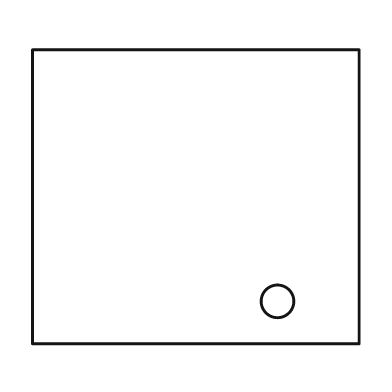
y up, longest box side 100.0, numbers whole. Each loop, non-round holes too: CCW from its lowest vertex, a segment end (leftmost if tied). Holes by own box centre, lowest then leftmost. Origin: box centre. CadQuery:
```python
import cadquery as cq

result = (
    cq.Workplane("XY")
    .moveTo(-50.0, -45.0)
    .lineTo(50.0, -45.0)
    .lineTo(50.0, 45.0)
    .lineTo(-50.0, 45.0)
    .close()
    .moveTo(25.0, -32.0)
    .circle(5.0)
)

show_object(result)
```